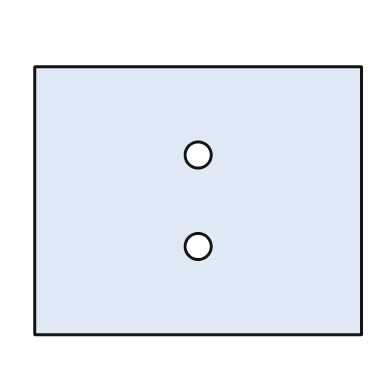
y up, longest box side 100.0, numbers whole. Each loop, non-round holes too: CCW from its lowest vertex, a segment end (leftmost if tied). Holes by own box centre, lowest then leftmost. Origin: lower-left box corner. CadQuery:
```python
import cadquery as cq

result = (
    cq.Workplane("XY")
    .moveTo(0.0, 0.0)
    .lineTo(100.0, 0.0)
    .lineTo(100.0, 82.0)
    .lineTo(0.0, 82.0)
    .close()
    .moveTo(50.0, 27.0)
    .circle(4.0)
    .moveTo(50.0, 55.0)
    .circle(4.0)
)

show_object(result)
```